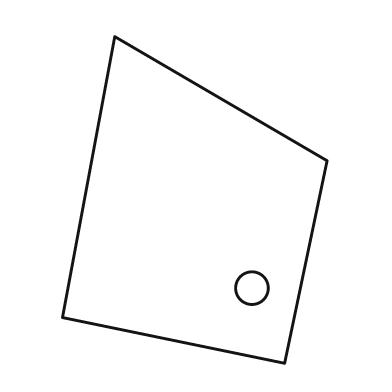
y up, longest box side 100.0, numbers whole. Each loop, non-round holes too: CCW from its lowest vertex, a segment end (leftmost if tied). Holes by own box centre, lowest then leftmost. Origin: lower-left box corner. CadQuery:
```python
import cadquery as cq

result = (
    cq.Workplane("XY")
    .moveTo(68.0, 0.0)
    .lineTo(81.0, 62.0)
    .lineTo(16.0, 100.0)
    .lineTo(0.0, 14.0)
    .close()
    .moveTo(58.0, 23.0)
    .circle(5.0)
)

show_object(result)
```